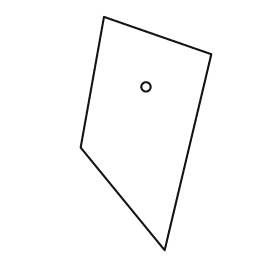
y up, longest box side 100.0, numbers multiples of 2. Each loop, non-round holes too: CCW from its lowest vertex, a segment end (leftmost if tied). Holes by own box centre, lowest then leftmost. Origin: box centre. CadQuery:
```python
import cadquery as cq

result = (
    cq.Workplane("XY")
    .moveTo(8.0, -50.0)
    .lineTo(28.0, 34.0)
    .lineTo(-18.0, 50.0)
    .lineTo(-28.0, -6.0)
    .close()
    .moveTo(0.0, 20.0)
    .circle(2.0)
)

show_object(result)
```